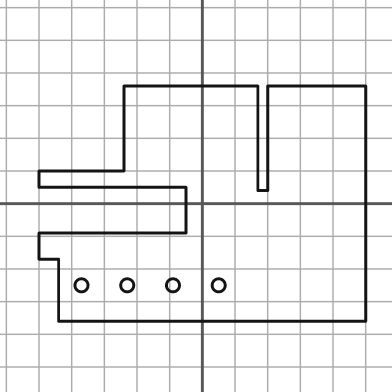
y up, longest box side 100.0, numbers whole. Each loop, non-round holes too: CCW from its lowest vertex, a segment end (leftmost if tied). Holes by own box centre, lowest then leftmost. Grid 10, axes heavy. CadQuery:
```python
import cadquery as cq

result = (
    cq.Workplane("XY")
    .moveTo(-44.0, -36.0)
    .lineTo(50.0, -36.0)
    .lineTo(50.0, 36.0)
    .lineTo(20.0, 36.0)
    .lineTo(20.0, 4.0)
    .lineTo(17.0, 4.0)
    .lineTo(17.0, 36.0)
    .lineTo(-24.0, 36.0)
    .lineTo(-24.0, 10.0)
    .lineTo(-50.0, 10.0)
    .lineTo(-50.0, 5.0)
    .lineTo(-5.0, 5.0)
    .lineTo(-5.0, -9.0)
    .lineTo(-50.0, -9.0)
    .lineTo(-50.0, -17.0)
    .lineTo(-44.0, -17.0)
    .close()
    .moveTo(-37.0, -25.0)
    .circle(2.0)
    .moveTo(-23.0, -25.0)
    .circle(2.0)
    .moveTo(-9.0, -25.0)
    .circle(2.0)
    .moveTo(5.0, -25.0)
    .circle(2.0)
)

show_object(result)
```